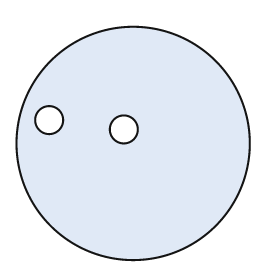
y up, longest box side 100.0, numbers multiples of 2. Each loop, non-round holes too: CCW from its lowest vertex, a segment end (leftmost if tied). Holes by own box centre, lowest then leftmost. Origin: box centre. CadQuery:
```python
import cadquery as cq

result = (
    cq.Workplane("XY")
    .moveTo(0.0, 0.0)
    .circle(50.0)
    .moveTo(-4.0, 6.0)
    .circle(6.0)
    .moveTo(-36.0, 10.0)
    .circle(6.0)
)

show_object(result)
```